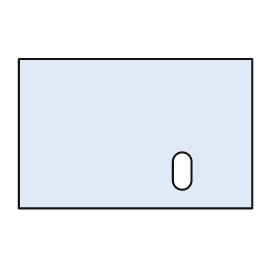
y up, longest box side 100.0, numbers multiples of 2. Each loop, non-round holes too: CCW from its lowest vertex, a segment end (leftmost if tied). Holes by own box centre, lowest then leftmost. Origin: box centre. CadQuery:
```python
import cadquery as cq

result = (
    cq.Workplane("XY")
    .moveTo(-50.0, -32.0)
    .lineTo(50.0, -32.0)
    .lineTo(50.0, 32.0)
    .lineTo(-50.0, 32.0)
    .close()
    .moveTo(16.0, -20.0)
    .threePointArc((20.0, -24.0), (24.0, -20.0))
    .lineTo(24.0, -12.0)
    .threePointArc((20.0, -8.0), (16.0, -12.0))
    .close()
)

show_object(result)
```